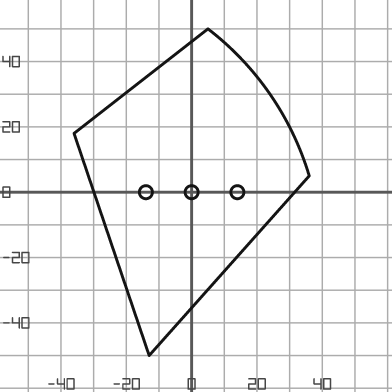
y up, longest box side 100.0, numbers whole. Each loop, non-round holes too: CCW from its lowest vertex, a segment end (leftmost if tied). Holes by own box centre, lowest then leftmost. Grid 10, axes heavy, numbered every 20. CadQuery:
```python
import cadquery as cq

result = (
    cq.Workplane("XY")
    .moveTo(-13.0, -50.0)
    .lineTo(36.0, 5.0)
    .threePointArc((24.0, 30.0), (5.0, 50.0))
    .lineTo(-36.0, 18.0)
    .close()
    .moveTo(-14.0, 0.0)
    .circle(2.0)
    .moveTo(0.0, 0.0)
    .circle(2.0)
    .moveTo(14.0, 0.0)
    .circle(2.0)
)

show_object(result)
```